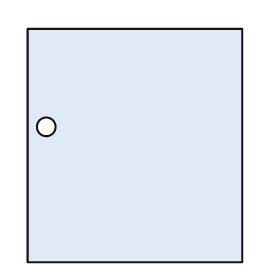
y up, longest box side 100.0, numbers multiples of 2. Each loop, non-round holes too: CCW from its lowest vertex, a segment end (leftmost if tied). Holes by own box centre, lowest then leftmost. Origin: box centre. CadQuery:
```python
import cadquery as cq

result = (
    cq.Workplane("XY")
    .moveTo(-46.0, -50.0)
    .lineTo(46.0, -50.0)
    .lineTo(46.0, 50.0)
    .lineTo(-46.0, 50.0)
    .close()
    .moveTo(-38.0, 8.0)
    .circle(4.0)
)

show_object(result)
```